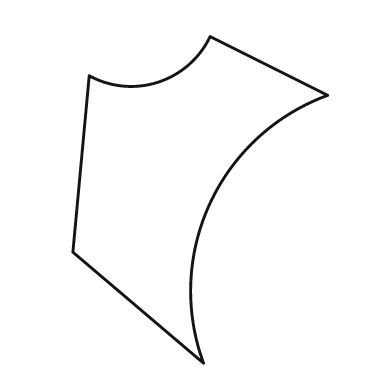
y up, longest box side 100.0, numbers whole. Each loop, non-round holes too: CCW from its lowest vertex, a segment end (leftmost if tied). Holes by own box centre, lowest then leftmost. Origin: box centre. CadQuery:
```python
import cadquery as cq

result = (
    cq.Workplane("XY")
    .moveTo(1.0, -50.0)
    .threePointArc((3.0, -1.0), (39.0, 32.0))
    .lineTo(3.0, 50.0)
    .threePointArc((-13.0, 36.0), (-34.0, 38.0))
    .lineTo(-39.0, -16.0)
    .close()
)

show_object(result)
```